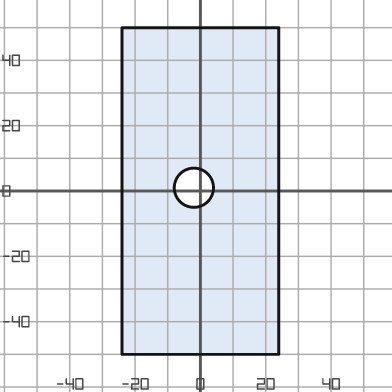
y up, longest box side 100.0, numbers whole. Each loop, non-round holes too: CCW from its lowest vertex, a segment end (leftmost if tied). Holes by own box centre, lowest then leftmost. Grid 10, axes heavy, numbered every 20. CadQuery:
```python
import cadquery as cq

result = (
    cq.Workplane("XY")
    .moveTo(-24.0, -50.0)
    .lineTo(24.0, -50.0)
    .lineTo(24.0, 50.0)
    .lineTo(-24.0, 50.0)
    .close()
    .moveTo(-2.0, 1.0)
    .circle(6.0)
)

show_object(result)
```